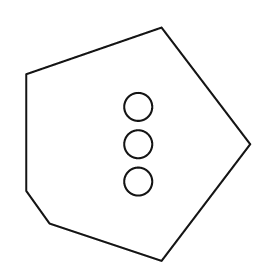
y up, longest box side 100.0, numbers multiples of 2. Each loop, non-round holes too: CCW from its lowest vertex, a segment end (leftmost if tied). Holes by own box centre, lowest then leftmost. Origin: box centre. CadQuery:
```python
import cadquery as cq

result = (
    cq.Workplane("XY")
    .moveTo(10.0, -50.0)
    .lineTo(48.0, 0.0)
    .lineTo(10.0, 50.0)
    .lineTo(-48.0, 30.0)
    .lineTo(-48.0, -20.0)
    .lineTo(-38.0, -34.0)
    .close()
    .moveTo(0.0, -16.0)
    .circle(6.0)
    .moveTo(0.0, 0.0)
    .circle(6.0)
    .moveTo(0.0, 16.0)
    .circle(6.0)
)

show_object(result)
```